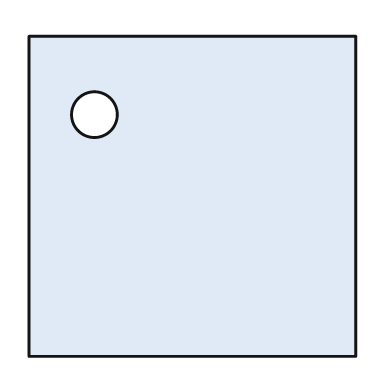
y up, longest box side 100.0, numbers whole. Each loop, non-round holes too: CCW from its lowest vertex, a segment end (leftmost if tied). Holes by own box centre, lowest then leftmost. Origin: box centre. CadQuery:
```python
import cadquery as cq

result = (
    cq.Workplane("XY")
    .moveTo(-50.0, -49.0)
    .lineTo(50.0, -49.0)
    .lineTo(50.0, 49.0)
    .lineTo(-50.0, 49.0)
    .close()
    .moveTo(-30.0, 25.0)
    .circle(7.0)
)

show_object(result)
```